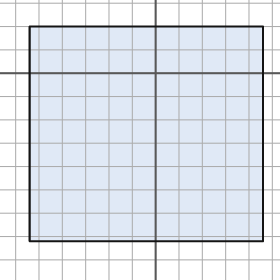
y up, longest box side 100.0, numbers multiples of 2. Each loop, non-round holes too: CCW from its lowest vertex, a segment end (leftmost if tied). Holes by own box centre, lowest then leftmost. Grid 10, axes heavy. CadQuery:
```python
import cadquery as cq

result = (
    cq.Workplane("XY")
    .moveTo(-54.0, -72.0)
    .lineTo(46.0, -72.0)
    .lineTo(46.0, 20.0)
    .lineTo(-54.0, 20.0)
    .close()
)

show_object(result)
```